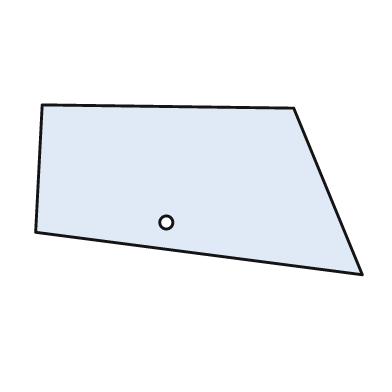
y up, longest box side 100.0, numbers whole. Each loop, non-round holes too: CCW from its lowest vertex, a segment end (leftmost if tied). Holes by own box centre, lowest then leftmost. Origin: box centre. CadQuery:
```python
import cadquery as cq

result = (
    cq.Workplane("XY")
    .moveTo(50.0, -26.0)
    .lineTo(29.0, 25.0)
    .lineTo(-48.0, 26.0)
    .lineTo(-50.0, -13.0)
    .close()
    .moveTo(-10.0, -10.0)
    .circle(2.0)
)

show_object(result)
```